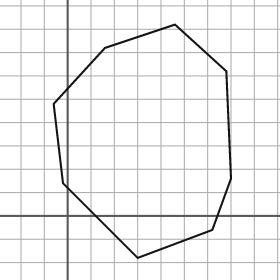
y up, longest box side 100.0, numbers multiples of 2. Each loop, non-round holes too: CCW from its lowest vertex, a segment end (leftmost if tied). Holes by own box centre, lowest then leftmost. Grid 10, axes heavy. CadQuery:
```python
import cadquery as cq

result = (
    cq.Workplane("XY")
    .moveTo(30.0, -18.0)
    .lineTo(62.0, -6.0)
    .lineTo(70.0, 16.0)
    .lineTo(68.0, 62.0)
    .lineTo(46.0, 82.0)
    .lineTo(16.0, 72.0)
    .lineTo(-6.0, 48.0)
    .lineTo(-2.0, 14.0)
    .close()
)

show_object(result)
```